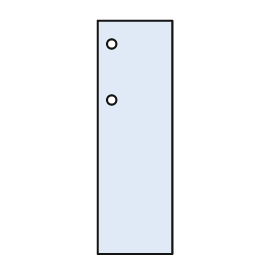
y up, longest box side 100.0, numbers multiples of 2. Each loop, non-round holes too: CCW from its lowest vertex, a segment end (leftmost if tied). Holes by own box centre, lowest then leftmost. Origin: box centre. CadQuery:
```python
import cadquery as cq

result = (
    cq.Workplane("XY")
    .moveTo(-16.0, -50.0)
    .lineTo(16.0, -50.0)
    .lineTo(16.0, 50.0)
    .lineTo(-16.0, 50.0)
    .close()
    .moveTo(-10.0, 16.0)
    .circle(2.0)
    .moveTo(-10.0, 40.0)
    .circle(2.0)
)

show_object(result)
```